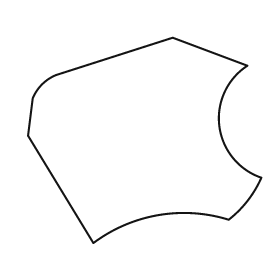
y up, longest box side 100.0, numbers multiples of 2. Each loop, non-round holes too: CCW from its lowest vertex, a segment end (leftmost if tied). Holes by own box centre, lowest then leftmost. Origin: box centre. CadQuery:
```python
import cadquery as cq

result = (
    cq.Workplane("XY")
    .moveTo(-22.0, -44.0)
    .threePointArc((6.0, -32.0), (36.0, -34.0))
    .threePointArc((44.0, -26.0), (50.0, -16.0))
    .threePointArc((32.0, 6.0), (44.0, 32.0))
    .lineTo(12.0, 44.0)
    .lineTo(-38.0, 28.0)
    .threePointArc((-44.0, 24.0), (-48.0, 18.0))
    .lineTo(-50.0, 2.0)
    .close()
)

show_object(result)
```